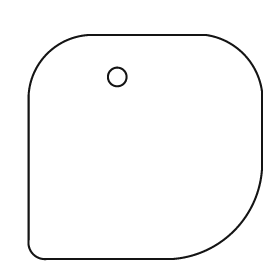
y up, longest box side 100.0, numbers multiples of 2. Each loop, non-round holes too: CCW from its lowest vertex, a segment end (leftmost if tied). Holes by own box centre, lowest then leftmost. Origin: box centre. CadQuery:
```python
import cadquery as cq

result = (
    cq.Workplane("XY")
    .moveTo(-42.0, -48.0)
    .lineTo(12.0, -48.0)
    .threePointArc((38.0, -36.0), (50.0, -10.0))
    .lineTo(50.0, 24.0)
    .threePointArc((42.0, 40.0), (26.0, 48.0))
    .lineTo(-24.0, 48.0)
    .threePointArc((-42.0, 40.0), (-50.0, 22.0))
    .lineTo(-50.0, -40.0)
    .threePointArc((-48.0, -46.0), (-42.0, -48.0))
    .close()
    .moveTo(-12.0, 30.0)
    .circle(4.0)
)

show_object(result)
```